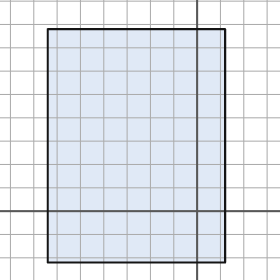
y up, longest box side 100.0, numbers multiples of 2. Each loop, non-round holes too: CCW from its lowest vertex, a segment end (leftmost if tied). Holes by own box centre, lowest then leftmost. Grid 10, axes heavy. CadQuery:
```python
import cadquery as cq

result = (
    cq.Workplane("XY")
    .moveTo(-64.0, -22.0)
    .lineTo(12.0, -22.0)
    .lineTo(12.0, 78.0)
    .lineTo(-64.0, 78.0)
    .close()
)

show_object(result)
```